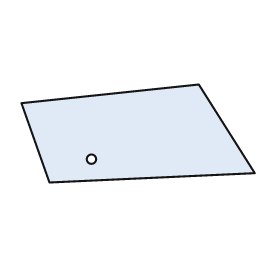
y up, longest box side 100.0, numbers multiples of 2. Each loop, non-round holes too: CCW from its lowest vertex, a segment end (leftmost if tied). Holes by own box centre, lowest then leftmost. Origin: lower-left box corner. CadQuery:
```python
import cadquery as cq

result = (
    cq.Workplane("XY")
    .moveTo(12.0, 0.0)
    .lineTo(100.0, 4.0)
    .lineTo(76.0, 42.0)
    .lineTo(0.0, 34.0)
    .close()
    .moveTo(30.0, 10.0)
    .circle(2.0)
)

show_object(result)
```